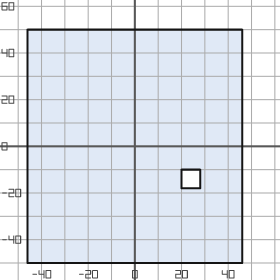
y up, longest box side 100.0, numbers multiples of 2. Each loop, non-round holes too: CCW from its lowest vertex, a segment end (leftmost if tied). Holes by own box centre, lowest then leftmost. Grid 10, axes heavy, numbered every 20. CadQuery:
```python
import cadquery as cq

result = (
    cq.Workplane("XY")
    .moveTo(-46.0, -50.0)
    .lineTo(46.0, -50.0)
    .lineTo(46.0, 50.0)
    .lineTo(-46.0, 50.0)
    .close()
    .moveTo(20.0, -18.0)
    .lineTo(28.0, -18.0)
    .lineTo(28.0, -10.0)
    .lineTo(20.0, -10.0)
    .close()
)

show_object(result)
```